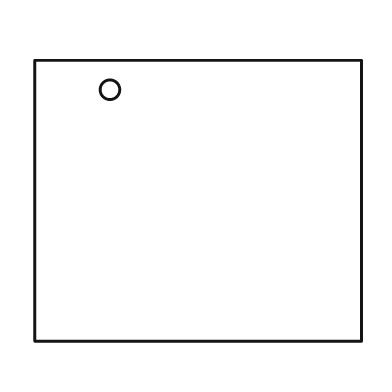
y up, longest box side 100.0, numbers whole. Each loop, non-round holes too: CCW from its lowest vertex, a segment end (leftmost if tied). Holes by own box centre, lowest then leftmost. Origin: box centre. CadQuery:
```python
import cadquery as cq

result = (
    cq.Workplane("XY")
    .moveTo(-50.0, -43.0)
    .lineTo(50.0, -43.0)
    .lineTo(50.0, 43.0)
    .lineTo(-50.0, 43.0)
    .close()
    .moveTo(-27.0, 34.0)
    .circle(3.0)
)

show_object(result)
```